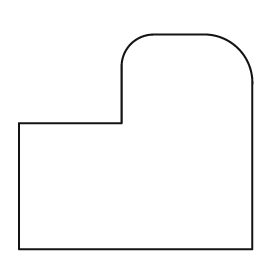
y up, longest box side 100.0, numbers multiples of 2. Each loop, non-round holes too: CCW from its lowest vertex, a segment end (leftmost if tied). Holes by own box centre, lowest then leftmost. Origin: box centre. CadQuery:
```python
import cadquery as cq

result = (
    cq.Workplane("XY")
    .moveTo(-50.0, -46.0)
    .lineTo(50.0, -46.0)
    .lineTo(50.0, 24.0)
    .threePointArc((44.0, 40.0), (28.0, 46.0))
    .lineTo(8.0, 46.0)
    .threePointArc((-2.0, 42.0), (-6.0, 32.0))
    .lineTo(-6.0, 8.0)
    .lineTo(-50.0, 8.0)
    .close()
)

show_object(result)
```